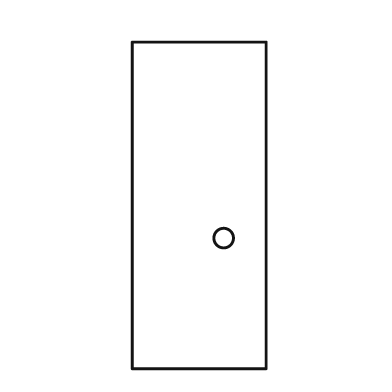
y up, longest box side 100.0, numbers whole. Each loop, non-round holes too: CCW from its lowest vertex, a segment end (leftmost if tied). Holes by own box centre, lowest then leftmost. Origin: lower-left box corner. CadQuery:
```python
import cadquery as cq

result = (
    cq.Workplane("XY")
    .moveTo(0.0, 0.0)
    .lineTo(41.0, 0.0)
    .lineTo(41.0, 100.0)
    .lineTo(0.0, 100.0)
    .close()
    .moveTo(28.0, 40.0)
    .circle(3.0)
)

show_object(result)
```